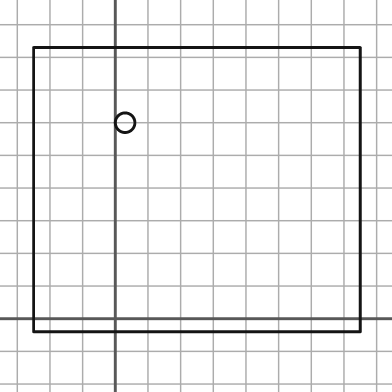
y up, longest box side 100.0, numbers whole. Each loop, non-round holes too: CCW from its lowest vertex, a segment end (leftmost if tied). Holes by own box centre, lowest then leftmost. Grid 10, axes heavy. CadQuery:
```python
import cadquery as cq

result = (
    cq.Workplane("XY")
    .moveTo(-25.0, -4.0)
    .lineTo(75.0, -4.0)
    .lineTo(75.0, 83.0)
    .lineTo(-25.0, 83.0)
    .close()
    .moveTo(3.0, 60.0)
    .circle(3.0)
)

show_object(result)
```